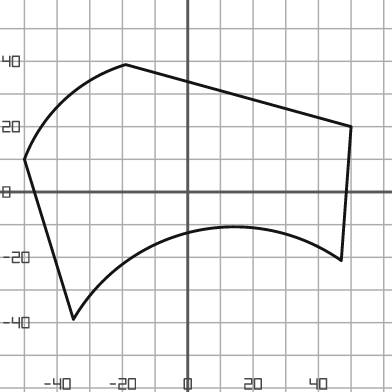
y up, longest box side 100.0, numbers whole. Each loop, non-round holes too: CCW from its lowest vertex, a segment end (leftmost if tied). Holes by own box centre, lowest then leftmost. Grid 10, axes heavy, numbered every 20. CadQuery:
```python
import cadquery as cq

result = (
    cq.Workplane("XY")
    .moveTo(-35.0, -39.0)
    .threePointArc((2.0, -12.0), (47.0, -21.0))
    .lineTo(50.0, 20.0)
    .lineTo(-19.0, 39.0)
    .threePointArc((-38.0, 28.0), (-50.0, 10.0))
    .close()
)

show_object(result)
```